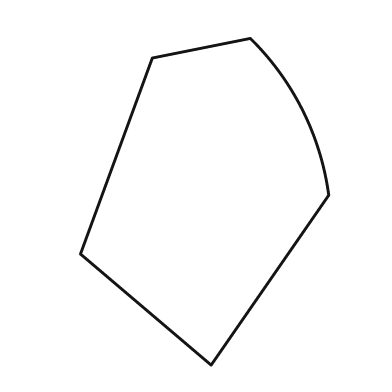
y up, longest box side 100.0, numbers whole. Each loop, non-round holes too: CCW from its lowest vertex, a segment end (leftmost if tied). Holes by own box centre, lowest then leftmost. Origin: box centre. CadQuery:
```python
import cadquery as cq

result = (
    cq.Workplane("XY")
    .moveTo(2.0, -50.0)
    .lineTo(38.0, 2.0)
    .threePointArc((30.0, 28.0), (14.0, 50.0))
    .lineTo(-16.0, 44.0)
    .lineTo(-38.0, -16.0)
    .close()
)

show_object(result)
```